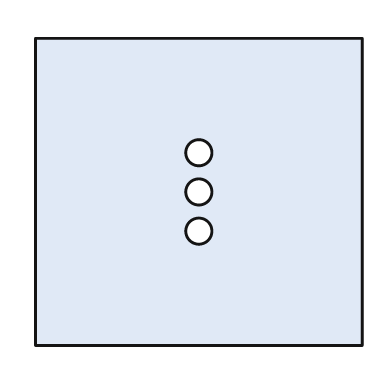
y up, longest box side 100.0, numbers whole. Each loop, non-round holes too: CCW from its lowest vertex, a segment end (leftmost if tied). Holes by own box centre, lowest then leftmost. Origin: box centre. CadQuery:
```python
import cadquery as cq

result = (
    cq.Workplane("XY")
    .moveTo(-50.0, -47.0)
    .lineTo(50.0, -47.0)
    .lineTo(50.0, 47.0)
    .lineTo(-50.0, 47.0)
    .close()
    .moveTo(0.0, -12.0)
    .circle(4.0)
    .moveTo(0.0, 0.0)
    .circle(4.0)
    .moveTo(0.0, 12.0)
    .circle(4.0)
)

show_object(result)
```